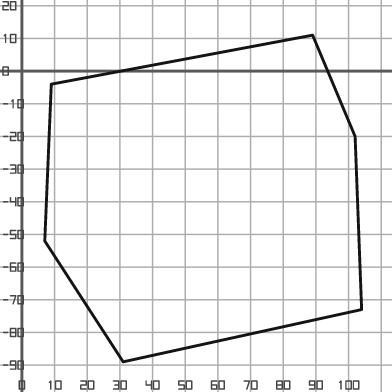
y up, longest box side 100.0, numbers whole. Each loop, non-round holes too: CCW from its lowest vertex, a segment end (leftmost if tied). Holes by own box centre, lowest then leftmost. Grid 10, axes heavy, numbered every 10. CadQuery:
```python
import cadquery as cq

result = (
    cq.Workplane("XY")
    .moveTo(31.0, -89.0)
    .lineTo(104.0, -73.0)
    .lineTo(102.0, -20.0)
    .lineTo(89.0, 11.0)
    .lineTo(9.0, -4.0)
    .lineTo(7.0, -52.0)
    .close()
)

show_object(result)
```